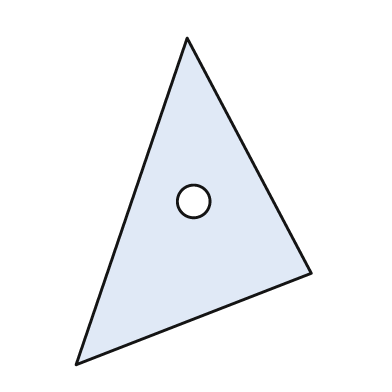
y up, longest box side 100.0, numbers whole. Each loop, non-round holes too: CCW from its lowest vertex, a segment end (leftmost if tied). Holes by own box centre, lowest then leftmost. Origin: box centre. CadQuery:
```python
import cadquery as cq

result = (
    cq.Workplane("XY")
    .moveTo(-36.0, -50.0)
    .lineTo(36.0, -22.0)
    .lineTo(-2.0, 50.0)
    .close()
    .moveTo(0.0, 0.0)
    .circle(5.0)
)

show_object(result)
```